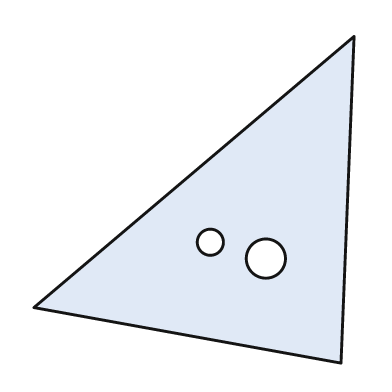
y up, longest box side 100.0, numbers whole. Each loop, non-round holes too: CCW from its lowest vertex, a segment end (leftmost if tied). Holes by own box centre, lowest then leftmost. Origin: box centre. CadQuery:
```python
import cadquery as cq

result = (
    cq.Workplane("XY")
    .moveTo(45.0, -50.0)
    .lineTo(49.0, 50.0)
    .lineTo(-49.0, -33.0)
    .close()
    .moveTo(22.0, -18.0)
    .circle(6.0)
    .moveTo(5.0, -13.0)
    .circle(4.0)
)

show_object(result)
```